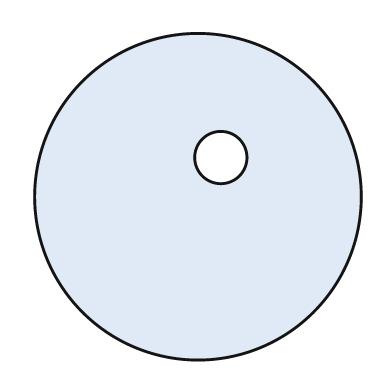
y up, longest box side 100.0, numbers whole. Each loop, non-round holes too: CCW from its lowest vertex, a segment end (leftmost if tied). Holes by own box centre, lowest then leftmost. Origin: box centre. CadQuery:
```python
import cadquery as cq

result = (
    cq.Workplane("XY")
    .moveTo(0.0, 0.0)
    .circle(50.0)
    .moveTo(7.0, 12.0)
    .circle(8.0)
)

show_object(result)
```